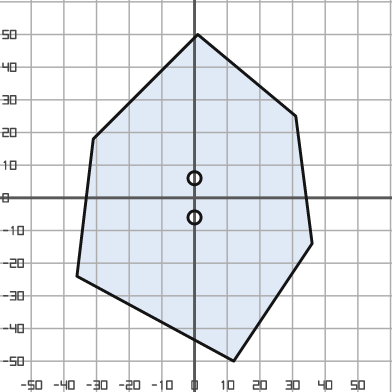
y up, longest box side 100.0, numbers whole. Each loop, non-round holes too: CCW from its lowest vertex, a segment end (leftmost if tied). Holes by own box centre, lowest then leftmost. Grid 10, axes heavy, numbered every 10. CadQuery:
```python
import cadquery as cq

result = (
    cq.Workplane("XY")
    .moveTo(12.0, -50.0)
    .lineTo(36.0, -14.0)
    .lineTo(31.0, 25.0)
    .lineTo(1.0, 50.0)
    .lineTo(-31.0, 18.0)
    .lineTo(-36.0, -24.0)
    .close()
    .moveTo(0.0, -6.0)
    .circle(2.0)
    .moveTo(0.0, 6.0)
    .circle(2.0)
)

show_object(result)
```